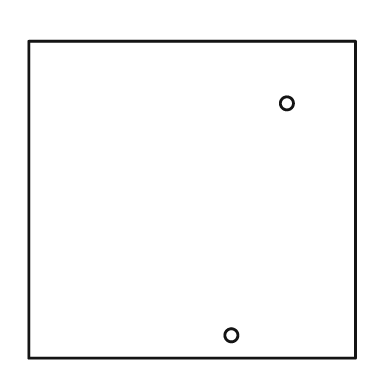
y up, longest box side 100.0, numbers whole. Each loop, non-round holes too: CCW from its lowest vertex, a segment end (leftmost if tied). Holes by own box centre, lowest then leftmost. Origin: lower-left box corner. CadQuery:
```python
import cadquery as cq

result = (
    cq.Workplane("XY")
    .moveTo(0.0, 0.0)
    .lineTo(100.0, 0.0)
    .lineTo(100.0, 97.0)
    .lineTo(0.0, 97.0)
    .close()
    .moveTo(62.0, 7.0)
    .circle(2.0)
    .moveTo(79.0, 78.0)
    .circle(2.0)
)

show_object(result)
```